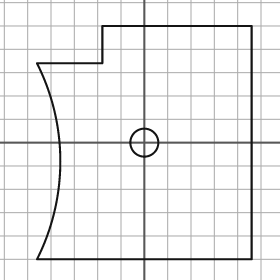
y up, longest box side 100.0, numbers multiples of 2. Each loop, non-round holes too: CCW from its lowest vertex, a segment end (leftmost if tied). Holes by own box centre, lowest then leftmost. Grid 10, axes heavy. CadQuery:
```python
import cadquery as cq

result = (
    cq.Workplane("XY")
    .moveTo(-46.0, -50.0)
    .lineTo(46.0, -50.0)
    .lineTo(46.0, 50.0)
    .lineTo(-18.0, 50.0)
    .lineTo(-18.0, 34.0)
    .lineTo(-46.0, 34.0)
    .threePointArc((-36.0, -8.0), (-46.0, -50.0))
    .close()
    .moveTo(0.0, 0.0)
    .circle(6.0)
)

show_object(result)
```